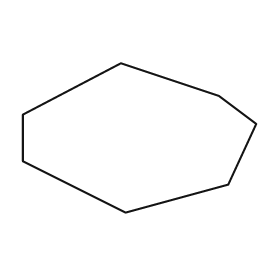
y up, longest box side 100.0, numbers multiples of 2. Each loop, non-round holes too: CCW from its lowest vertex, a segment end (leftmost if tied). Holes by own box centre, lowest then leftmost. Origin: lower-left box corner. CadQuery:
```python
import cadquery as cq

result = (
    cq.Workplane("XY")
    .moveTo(44.0, 0.0)
    .lineTo(88.0, 12.0)
    .lineTo(100.0, 38.0)
    .lineTo(84.0, 50.0)
    .lineTo(42.0, 64.0)
    .lineTo(0.0, 42.0)
    .lineTo(0.0, 22.0)
    .close()
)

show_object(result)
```